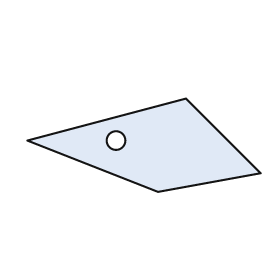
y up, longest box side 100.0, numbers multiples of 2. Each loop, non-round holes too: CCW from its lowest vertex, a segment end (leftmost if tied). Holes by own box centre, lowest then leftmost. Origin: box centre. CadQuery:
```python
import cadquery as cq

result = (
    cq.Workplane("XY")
    .moveTo(6.0, -20.0)
    .lineTo(50.0, -12.0)
    .lineTo(18.0, 20.0)
    .lineTo(-50.0, 2.0)
    .close()
    .moveTo(-12.0, 2.0)
    .circle(4.0)
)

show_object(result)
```